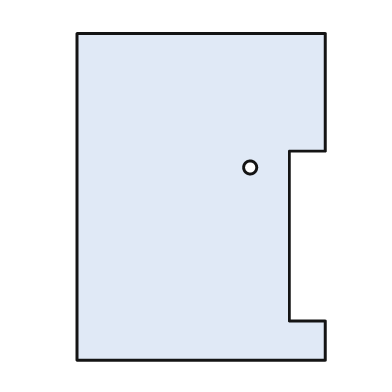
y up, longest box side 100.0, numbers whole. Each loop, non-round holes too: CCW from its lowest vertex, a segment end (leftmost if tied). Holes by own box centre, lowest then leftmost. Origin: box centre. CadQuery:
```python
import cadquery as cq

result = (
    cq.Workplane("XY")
    .moveTo(-38.0, -50.0)
    .lineTo(38.0, -50.0)
    .lineTo(38.0, -38.0)
    .lineTo(27.0, -38.0)
    .lineTo(27.0, 14.0)
    .lineTo(38.0, 14.0)
    .lineTo(38.0, 50.0)
    .lineTo(-38.0, 50.0)
    .close()
    .moveTo(15.0, 9.0)
    .circle(2.0)
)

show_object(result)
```